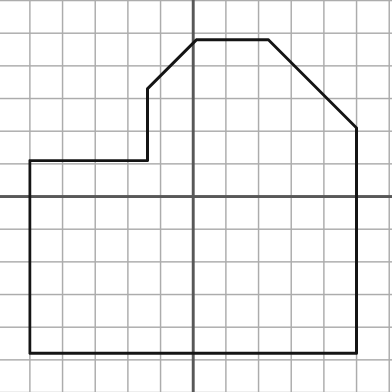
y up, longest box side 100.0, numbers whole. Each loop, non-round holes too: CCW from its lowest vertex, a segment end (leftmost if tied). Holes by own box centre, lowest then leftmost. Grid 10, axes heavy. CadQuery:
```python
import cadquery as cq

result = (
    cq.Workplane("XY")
    .moveTo(-50.0, -48.0)
    .lineTo(50.0, -48.0)
    .lineTo(50.0, 21.0)
    .lineTo(23.0, 48.0)
    .lineTo(1.0, 48.0)
    .lineTo(-14.0, 33.0)
    .lineTo(-14.0, 11.0)
    .lineTo(-50.0, 11.0)
    .close()
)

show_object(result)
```